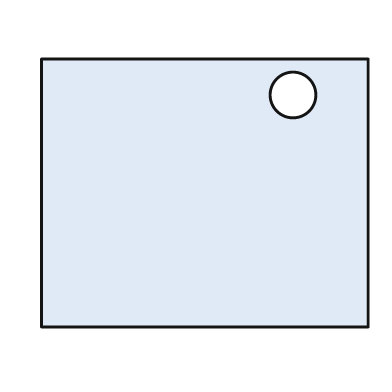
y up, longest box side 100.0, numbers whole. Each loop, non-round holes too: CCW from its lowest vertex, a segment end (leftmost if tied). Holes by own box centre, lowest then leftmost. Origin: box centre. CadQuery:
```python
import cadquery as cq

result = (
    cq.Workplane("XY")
    .moveTo(-50.0, -41.0)
    .lineTo(50.0, -41.0)
    .lineTo(50.0, 41.0)
    .lineTo(-50.0, 41.0)
    .close()
    .moveTo(27.0, 30.0)
    .circle(7.0)
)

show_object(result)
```